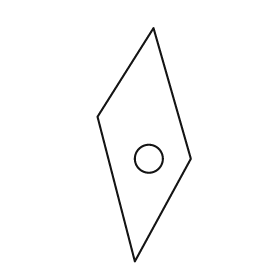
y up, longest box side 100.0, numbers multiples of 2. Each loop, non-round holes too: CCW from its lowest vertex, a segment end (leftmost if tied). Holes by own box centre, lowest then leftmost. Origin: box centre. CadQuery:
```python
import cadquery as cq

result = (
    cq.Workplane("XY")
    .moveTo(-4.0, -50.0)
    .lineTo(20.0, -6.0)
    .lineTo(4.0, 50.0)
    .lineTo(-20.0, 12.0)
    .close()
    .moveTo(2.0, -6.0)
    .circle(6.0)
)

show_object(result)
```